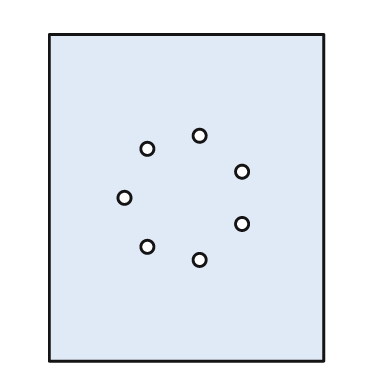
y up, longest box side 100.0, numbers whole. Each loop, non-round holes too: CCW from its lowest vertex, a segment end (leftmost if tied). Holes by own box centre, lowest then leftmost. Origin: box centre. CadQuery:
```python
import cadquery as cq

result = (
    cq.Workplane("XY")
    .moveTo(-42.0, -50.0)
    .lineTo(42.0, -50.0)
    .lineTo(42.0, 50.0)
    .lineTo(-42.0, 50.0)
    .close()
    .moveTo(4.0, -19.0)
    .circle(2.0)
    .moveTo(-12.0, -15.0)
    .circle(2.0)
    .moveTo(17.0, -8.0)
    .circle(2.0)
    .moveTo(-19.0, 0.0)
    .circle(2.0)
    .moveTo(17.0, 8.0)
    .circle(2.0)
    .moveTo(-12.0, 15.0)
    .circle(2.0)
    .moveTo(4.0, 19.0)
    .circle(2.0)
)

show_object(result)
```